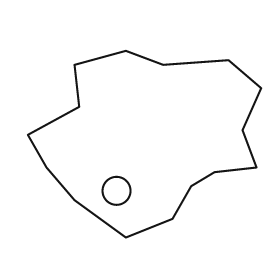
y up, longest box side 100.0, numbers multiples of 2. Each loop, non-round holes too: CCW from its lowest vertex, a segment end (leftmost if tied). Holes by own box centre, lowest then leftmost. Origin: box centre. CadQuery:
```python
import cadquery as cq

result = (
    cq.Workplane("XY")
    .moveTo(-8.0, -40.0)
    .lineTo(12.0, -32.0)
    .lineTo(20.0, -18.0)
    .lineTo(30.0, -12.0)
    .lineTo(48.0, -10.0)
    .lineTo(42.0, 6.0)
    .lineTo(50.0, 24.0)
    .lineTo(36.0, 36.0)
    .lineTo(8.0, 34.0)
    .lineTo(-8.0, 40.0)
    .lineTo(-30.0, 34.0)
    .lineTo(-28.0, 16.0)
    .lineTo(-50.0, 4.0)
    .lineTo(-42.0, -10.0)
    .lineTo(-30.0, -24.0)
    .close()
    .moveTo(-12.0, -20.0)
    .circle(6.0)
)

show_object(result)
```